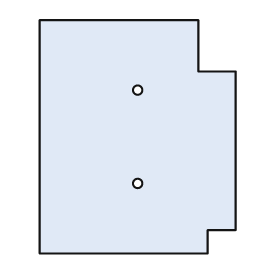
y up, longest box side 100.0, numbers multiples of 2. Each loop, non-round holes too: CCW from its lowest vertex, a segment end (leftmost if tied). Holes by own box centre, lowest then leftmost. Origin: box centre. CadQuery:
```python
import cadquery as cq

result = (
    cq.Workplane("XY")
    .moveTo(-42.0, -50.0)
    .lineTo(30.0, -50.0)
    .lineTo(30.0, -40.0)
    .lineTo(42.0, -40.0)
    .lineTo(42.0, 28.0)
    .lineTo(26.0, 28.0)
    .lineTo(26.0, 50.0)
    .lineTo(-42.0, 50.0)
    .close()
    .moveTo(0.0, -20.0)
    .circle(2.0)
    .moveTo(0.0, 20.0)
    .circle(2.0)
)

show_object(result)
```